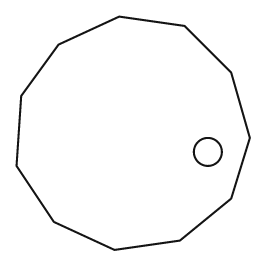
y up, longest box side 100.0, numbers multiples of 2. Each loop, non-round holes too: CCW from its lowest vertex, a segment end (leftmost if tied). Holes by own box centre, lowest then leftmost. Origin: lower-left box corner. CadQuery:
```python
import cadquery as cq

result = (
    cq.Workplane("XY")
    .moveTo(42.0, 0.0)
    .lineTo(70.0, 4.0)
    .lineTo(92.0, 22.0)
    .lineTo(100.0, 48.0)
    .lineTo(92.0, 76.0)
    .lineTo(72.0, 96.0)
    .lineTo(44.0, 100.0)
    .lineTo(18.0, 88.0)
    .lineTo(2.0, 66.0)
    .lineTo(0.0, 36.0)
    .lineTo(16.0, 12.0)
    .close()
    .moveTo(82.0, 42.0)
    .circle(6.0)
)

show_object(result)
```